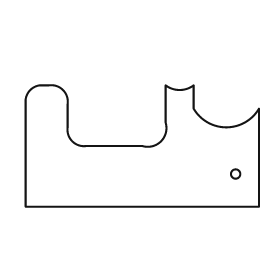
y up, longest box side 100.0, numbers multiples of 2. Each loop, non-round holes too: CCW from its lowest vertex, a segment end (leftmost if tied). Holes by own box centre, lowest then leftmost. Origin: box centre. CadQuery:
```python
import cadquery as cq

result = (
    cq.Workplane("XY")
    .moveTo(-50.0, -26.0)
    .lineTo(50.0, -26.0)
    .lineTo(50.0, 16.0)
    .threePointArc((36.0, 8.0), (22.0, 16.0))
    .lineTo(22.0, 26.0)
    .threePointArc((16.0, 24.0), (10.0, 26.0))
    .lineTo(10.0, 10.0)
    .threePointArc((8.0, 2.0), (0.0, 0.0))
    .lineTo(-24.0, 0.0)
    .threePointArc((-30.0, 2.0), (-32.0, 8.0))
    .lineTo(-32.0, 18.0)
    .threePointArc((-34.0, 24.0), (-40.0, 26.0))
    .lineTo(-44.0, 26.0)
    .threePointArc((-48.0, 24.0), (-50.0, 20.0))
    .close()
    .moveTo(40.0, -12.0)
    .circle(2.0)
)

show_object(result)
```